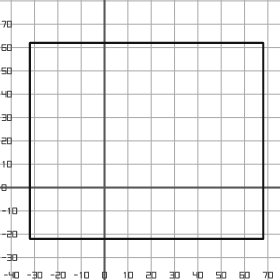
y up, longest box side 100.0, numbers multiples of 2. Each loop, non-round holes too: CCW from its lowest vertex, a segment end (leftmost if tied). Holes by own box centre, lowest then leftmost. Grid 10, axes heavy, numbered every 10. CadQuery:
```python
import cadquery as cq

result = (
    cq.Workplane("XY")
    .moveTo(-32.0, -22.0)
    .lineTo(68.0, -22.0)
    .lineTo(68.0, 62.0)
    .lineTo(-32.0, 62.0)
    .close()
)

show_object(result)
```